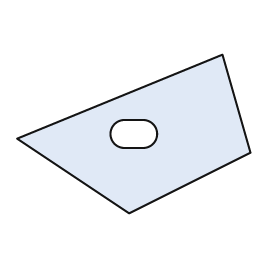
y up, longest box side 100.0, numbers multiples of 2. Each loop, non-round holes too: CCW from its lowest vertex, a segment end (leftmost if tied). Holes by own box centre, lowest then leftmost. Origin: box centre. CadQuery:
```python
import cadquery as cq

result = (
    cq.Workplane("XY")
    .moveTo(-2.0, -34.0)
    .lineTo(50.0, -8.0)
    .lineTo(38.0, 34.0)
    .lineTo(-50.0, -2.0)
    .close()
    .moveTo(-4.0, -6.0)
    .lineTo(4.0, -6.0)
    .threePointArc((10.0, 0.0), (4.0, 6.0))
    .lineTo(-4.0, 6.0)
    .threePointArc((-10.0, 0.0), (-4.0, -6.0))
    .close()
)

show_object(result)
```